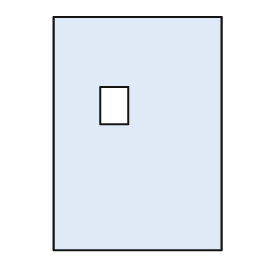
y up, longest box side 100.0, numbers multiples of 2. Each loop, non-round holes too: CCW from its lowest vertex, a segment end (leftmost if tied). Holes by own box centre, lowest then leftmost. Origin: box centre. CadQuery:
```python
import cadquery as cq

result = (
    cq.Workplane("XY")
    .moveTo(-36.0, -50.0)
    .lineTo(36.0, -50.0)
    .lineTo(36.0, 50.0)
    .lineTo(-36.0, 50.0)
    .close()
    .moveTo(-16.0, 4.0)
    .lineTo(-4.0, 4.0)
    .lineTo(-4.0, 20.0)
    .lineTo(-16.0, 20.0)
    .close()
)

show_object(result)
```